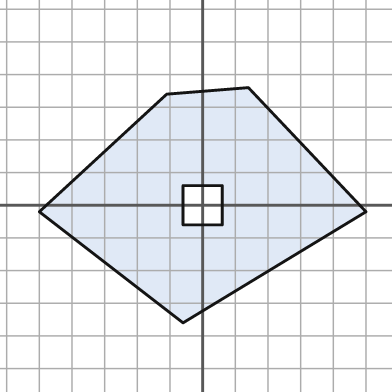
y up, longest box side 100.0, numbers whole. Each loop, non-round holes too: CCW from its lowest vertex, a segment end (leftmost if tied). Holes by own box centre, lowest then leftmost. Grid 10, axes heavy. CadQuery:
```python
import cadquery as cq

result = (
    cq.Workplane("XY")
    .moveTo(-6.0, -36.0)
    .lineTo(50.0, -2.0)
    .lineTo(14.0, 36.0)
    .lineTo(-11.0, 34.0)
    .lineTo(-50.0, -2.0)
    .close()
    .moveTo(-6.0, -6.0)
    .lineTo(6.0, -6.0)
    .lineTo(6.0, 6.0)
    .lineTo(-6.0, 6.0)
    .close()
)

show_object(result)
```